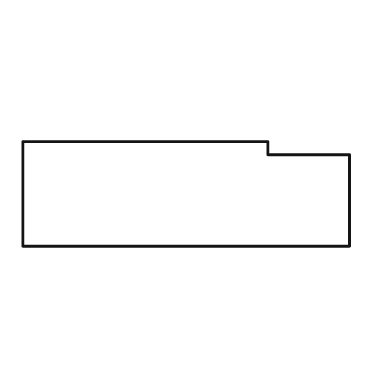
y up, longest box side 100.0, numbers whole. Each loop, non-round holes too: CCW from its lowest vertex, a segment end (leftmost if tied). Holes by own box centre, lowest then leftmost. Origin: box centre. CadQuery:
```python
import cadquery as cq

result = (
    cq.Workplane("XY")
    .moveTo(-50.0, -16.0)
    .lineTo(50.0, -16.0)
    .lineTo(50.0, 12.0)
    .lineTo(25.0, 12.0)
    .lineTo(25.0, 16.0)
    .lineTo(-50.0, 16.0)
    .close()
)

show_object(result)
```